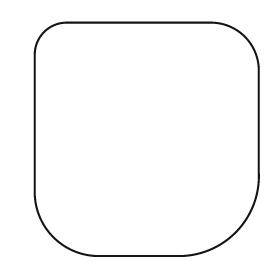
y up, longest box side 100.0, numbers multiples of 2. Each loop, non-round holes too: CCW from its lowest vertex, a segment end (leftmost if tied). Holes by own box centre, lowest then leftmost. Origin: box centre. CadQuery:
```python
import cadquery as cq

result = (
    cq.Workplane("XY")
    .moveTo(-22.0, -50.0)
    .lineTo(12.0, -50.0)
    .threePointArc((38.0, -40.0), (48.0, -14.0))
    .lineTo(48.0, 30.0)
    .threePointArc((42.0, 44.0), (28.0, 50.0))
    .lineTo(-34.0, 50.0)
    .threePointArc((-44.0, 46.0), (-48.0, 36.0))
    .lineTo(-48.0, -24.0)
    .threePointArc((-40.0, -42.0), (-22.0, -50.0))
    .close()
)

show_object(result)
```